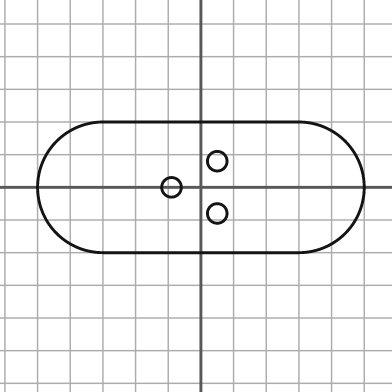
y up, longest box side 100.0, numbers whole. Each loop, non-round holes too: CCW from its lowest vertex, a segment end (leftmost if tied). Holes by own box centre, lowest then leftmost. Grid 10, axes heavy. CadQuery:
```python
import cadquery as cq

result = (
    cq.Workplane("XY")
    .moveTo(-30.0, -20.0)
    .lineTo(30.0, -20.0)
    .threePointArc((50.0, 0.0), (30.0, 20.0))
    .lineTo(-30.0, 20.0)
    .threePointArc((-50.0, 0.0), (-30.0, -20.0))
    .close()
    .moveTo(5.0, -8.0)
    .circle(3.0)
    .moveTo(-9.0, 0.0)
    .circle(3.0)
    .moveTo(5.0, 8.0)
    .circle(3.0)
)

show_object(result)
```